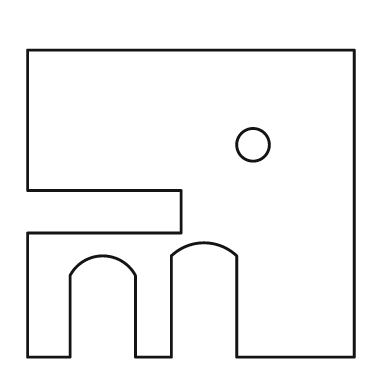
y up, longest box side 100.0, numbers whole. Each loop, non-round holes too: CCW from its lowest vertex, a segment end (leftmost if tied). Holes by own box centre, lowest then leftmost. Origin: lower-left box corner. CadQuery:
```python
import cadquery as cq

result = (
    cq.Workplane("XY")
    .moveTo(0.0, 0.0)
    .lineTo(13.0, 0.0)
    .lineTo(13.0, 25.0)
    .threePointArc((23.0, 31.0), (33.0, 25.0))
    .lineTo(33.0, 0.0)
    .lineTo(44.0, 0.0)
    .lineTo(44.0, 31.0)
    .threePointArc((54.0, 35.0), (64.0, 31.0))
    .lineTo(64.0, 0.0)
    .lineTo(100.0, 0.0)
    .lineTo(100.0, 94.0)
    .lineTo(0.0, 94.0)
    .lineTo(0.0, 51.0)
    .lineTo(47.0, 51.0)
    .lineTo(47.0, 38.0)
    .lineTo(0.0, 38.0)
    .close()
    .moveTo(69.0, 65.0)
    .circle(5.0)
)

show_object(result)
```